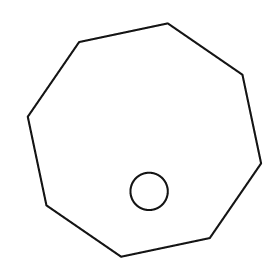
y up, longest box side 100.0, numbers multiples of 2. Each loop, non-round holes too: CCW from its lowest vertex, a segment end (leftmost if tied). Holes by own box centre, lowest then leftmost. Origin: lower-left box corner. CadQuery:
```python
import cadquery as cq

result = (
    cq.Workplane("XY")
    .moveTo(40.0, 0.0)
    .lineTo(78.0, 8.0)
    .lineTo(100.0, 40.0)
    .lineTo(92.0, 78.0)
    .lineTo(60.0, 100.0)
    .lineTo(22.0, 92.0)
    .lineTo(0.0, 60.0)
    .lineTo(8.0, 22.0)
    .close()
    .moveTo(52.0, 28.0)
    .circle(8.0)
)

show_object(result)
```